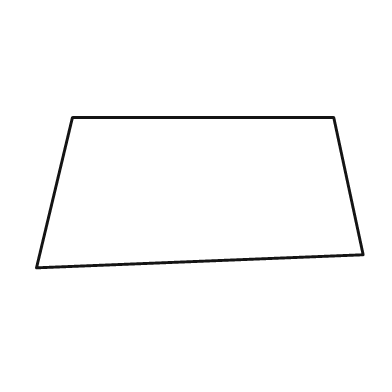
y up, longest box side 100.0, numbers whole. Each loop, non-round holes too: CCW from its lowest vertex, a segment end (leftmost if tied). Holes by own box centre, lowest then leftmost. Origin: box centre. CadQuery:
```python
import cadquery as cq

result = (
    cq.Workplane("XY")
    .moveTo(-50.0, -23.0)
    .lineTo(50.0, -19.0)
    .lineTo(41.0, 23.0)
    .lineTo(-39.0, 23.0)
    .close()
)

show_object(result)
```